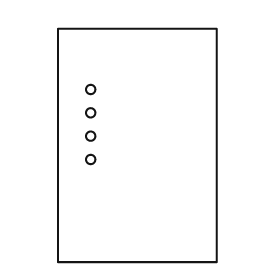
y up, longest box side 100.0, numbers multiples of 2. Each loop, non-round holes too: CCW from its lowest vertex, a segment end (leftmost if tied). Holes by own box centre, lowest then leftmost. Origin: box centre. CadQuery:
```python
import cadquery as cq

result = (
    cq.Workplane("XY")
    .moveTo(-34.0, -50.0)
    .lineTo(34.0, -50.0)
    .lineTo(34.0, 50.0)
    .lineTo(-34.0, 50.0)
    .close()
    .moveTo(-20.0, -6.0)
    .circle(2.0)
    .moveTo(-20.0, 4.0)
    .circle(2.0)
    .moveTo(-20.0, 14.0)
    .circle(2.0)
    .moveTo(-20.0, 24.0)
    .circle(2.0)
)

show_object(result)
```